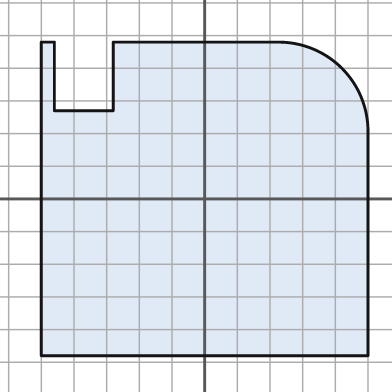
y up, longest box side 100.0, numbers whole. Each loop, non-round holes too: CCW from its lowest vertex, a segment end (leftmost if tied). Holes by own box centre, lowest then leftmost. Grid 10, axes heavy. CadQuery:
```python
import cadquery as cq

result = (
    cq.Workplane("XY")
    .moveTo(-50.0, -48.0)
    .lineTo(50.0, -48.0)
    .lineTo(50.0, 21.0)
    .threePointArc((42.0, 40.0), (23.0, 48.0))
    .lineTo(-28.0, 48.0)
    .lineTo(-28.0, 27.0)
    .lineTo(-46.0, 27.0)
    .lineTo(-46.0, 48.0)
    .lineTo(-50.0, 48.0)
    .close()
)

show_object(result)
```